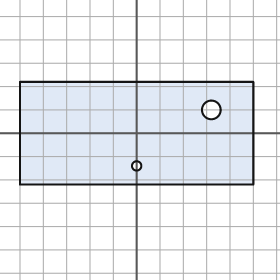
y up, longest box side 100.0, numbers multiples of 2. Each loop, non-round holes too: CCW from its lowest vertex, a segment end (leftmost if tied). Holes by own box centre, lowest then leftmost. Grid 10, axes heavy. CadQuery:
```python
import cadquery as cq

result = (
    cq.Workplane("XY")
    .moveTo(-50.0, -22.0)
    .lineTo(50.0, -22.0)
    .lineTo(50.0, 22.0)
    .lineTo(-50.0, 22.0)
    .close()
    .moveTo(0.0, -14.0)
    .circle(2.0)
    .moveTo(32.0, 10.0)
    .circle(4.0)
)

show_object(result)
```